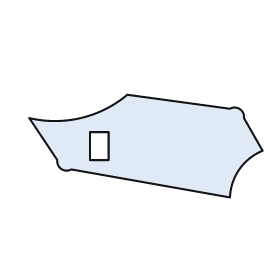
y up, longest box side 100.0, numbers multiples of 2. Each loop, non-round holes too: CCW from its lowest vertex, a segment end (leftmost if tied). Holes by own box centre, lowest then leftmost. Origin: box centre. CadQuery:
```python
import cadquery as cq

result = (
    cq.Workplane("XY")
    .moveTo(36.0, -22.0)
    .threePointArc((40.0, -10.0), (50.0, -2.0))
    .lineTo(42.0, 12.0)
    .threePointArc((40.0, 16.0), (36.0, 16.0))
    .lineTo(-8.0, 22.0)
    .threePointArc((-28.0, 12.0), (-50.0, 12.0))
    .lineTo(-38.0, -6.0)
    .threePointArc((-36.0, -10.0), (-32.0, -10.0))
    .close()
    .moveTo(-24.0, -6.0)
    .lineTo(-16.0, -6.0)
    .lineTo(-16.0, 6.0)
    .lineTo(-24.0, 6.0)
    .close()
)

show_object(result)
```